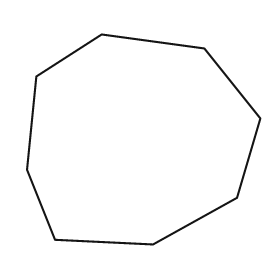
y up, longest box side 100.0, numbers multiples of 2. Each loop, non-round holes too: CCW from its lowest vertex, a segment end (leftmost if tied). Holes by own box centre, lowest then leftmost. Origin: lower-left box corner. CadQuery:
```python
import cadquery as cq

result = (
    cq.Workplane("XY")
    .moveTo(54.0, 0.0)
    .lineTo(90.0, 20.0)
    .lineTo(100.0, 54.0)
    .lineTo(76.0, 84.0)
    .lineTo(32.0, 90.0)
    .lineTo(4.0, 72.0)
    .lineTo(0.0, 32.0)
    .lineTo(12.0, 2.0)
    .close()
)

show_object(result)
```